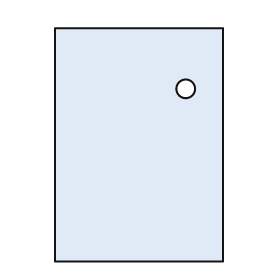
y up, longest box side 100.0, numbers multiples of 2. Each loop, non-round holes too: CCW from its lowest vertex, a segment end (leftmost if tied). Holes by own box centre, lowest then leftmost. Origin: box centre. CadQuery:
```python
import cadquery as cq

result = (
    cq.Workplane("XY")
    .moveTo(-36.0, -50.0)
    .lineTo(36.0, -50.0)
    .lineTo(36.0, 50.0)
    .lineTo(-36.0, 50.0)
    .close()
    .moveTo(20.0, 24.0)
    .circle(4.0)
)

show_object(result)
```